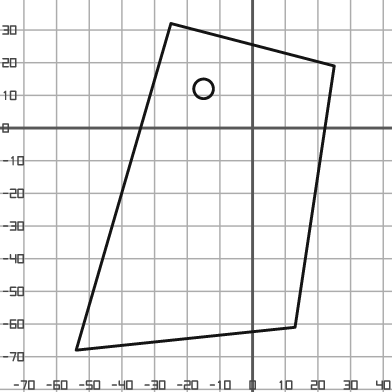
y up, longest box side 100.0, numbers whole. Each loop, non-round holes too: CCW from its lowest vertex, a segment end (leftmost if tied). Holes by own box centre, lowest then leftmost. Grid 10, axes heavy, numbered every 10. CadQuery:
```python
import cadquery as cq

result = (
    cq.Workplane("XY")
    .moveTo(-54.0, -68.0)
    .lineTo(13.0, -61.0)
    .lineTo(25.0, 19.0)
    .lineTo(-25.0, 32.0)
    .close()
    .moveTo(-15.0, 12.0)
    .circle(3.0)
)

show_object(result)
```